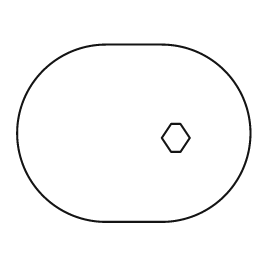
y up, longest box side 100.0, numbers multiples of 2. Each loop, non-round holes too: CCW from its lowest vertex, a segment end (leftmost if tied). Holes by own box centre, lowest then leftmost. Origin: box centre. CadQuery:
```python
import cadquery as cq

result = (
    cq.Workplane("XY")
    .moveTo(-12.0, -38.0)
    .lineTo(12.0, -38.0)
    .threePointArc((50.0, 0.0), (12.0, 38.0))
    .lineTo(-12.0, 38.0)
    .threePointArc((-50.0, 0.0), (-12.0, -38.0))
    .close()
    .moveTo(16.0, -8.0)
    .lineTo(20.0, -8.0)
    .lineTo(24.0, -2.0)
    .lineTo(20.0, 4.0)
    .lineTo(16.0, 4.0)
    .lineTo(12.0, -2.0)
    .close()
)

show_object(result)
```